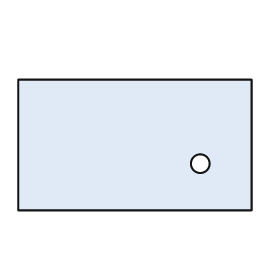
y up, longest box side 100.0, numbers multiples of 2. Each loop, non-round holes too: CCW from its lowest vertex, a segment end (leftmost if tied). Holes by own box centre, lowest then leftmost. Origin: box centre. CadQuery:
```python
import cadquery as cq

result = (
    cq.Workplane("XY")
    .moveTo(-50.0, -28.0)
    .lineTo(50.0, -28.0)
    .lineTo(50.0, 28.0)
    .lineTo(-50.0, 28.0)
    .close()
    .moveTo(28.0, -8.0)
    .circle(4.0)
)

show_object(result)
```